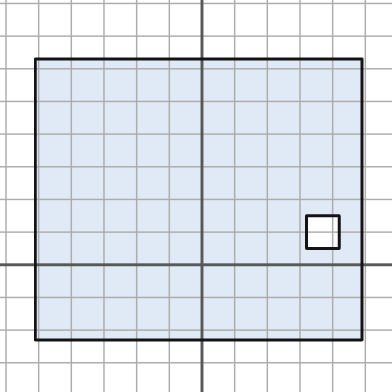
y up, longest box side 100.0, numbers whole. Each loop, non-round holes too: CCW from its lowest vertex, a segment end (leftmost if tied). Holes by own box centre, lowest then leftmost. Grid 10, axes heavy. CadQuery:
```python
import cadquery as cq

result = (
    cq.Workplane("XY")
    .moveTo(-51.0, -23.0)
    .lineTo(49.0, -23.0)
    .lineTo(49.0, 63.0)
    .lineTo(-51.0, 63.0)
    .close()
    .moveTo(32.0, 5.0)
    .lineTo(42.0, 5.0)
    .lineTo(42.0, 15.0)
    .lineTo(32.0, 15.0)
    .close()
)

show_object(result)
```